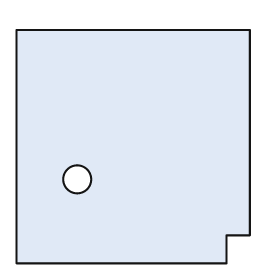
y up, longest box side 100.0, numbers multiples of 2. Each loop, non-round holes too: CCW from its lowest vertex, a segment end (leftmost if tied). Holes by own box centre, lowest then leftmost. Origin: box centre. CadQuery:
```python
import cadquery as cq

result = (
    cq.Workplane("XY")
    .moveTo(-50.0, -50.0)
    .lineTo(40.0, -50.0)
    .lineTo(40.0, -38.0)
    .lineTo(50.0, -38.0)
    .lineTo(50.0, 50.0)
    .lineTo(-50.0, 50.0)
    .close()
    .moveTo(-24.0, -14.0)
    .circle(6.0)
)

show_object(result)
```